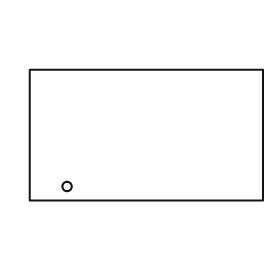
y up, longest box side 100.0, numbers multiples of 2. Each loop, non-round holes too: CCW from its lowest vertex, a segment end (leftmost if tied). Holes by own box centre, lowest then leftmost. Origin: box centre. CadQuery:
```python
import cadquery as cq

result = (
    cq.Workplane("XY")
    .moveTo(-50.0, -28.0)
    .lineTo(50.0, -28.0)
    .lineTo(50.0, 28.0)
    .lineTo(-50.0, 28.0)
    .close()
    .moveTo(-34.0, -22.0)
    .circle(2.0)
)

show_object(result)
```